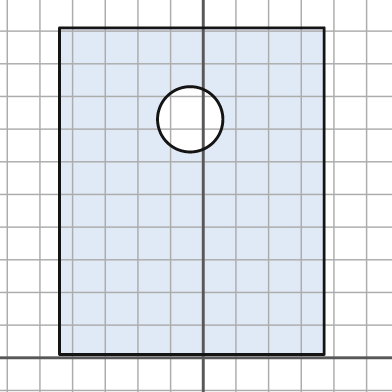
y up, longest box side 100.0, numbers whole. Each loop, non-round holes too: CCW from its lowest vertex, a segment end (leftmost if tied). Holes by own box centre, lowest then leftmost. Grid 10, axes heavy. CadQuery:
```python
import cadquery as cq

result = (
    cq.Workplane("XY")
    .moveTo(-44.0, 1.0)
    .lineTo(37.0, 1.0)
    .lineTo(37.0, 101.0)
    .lineTo(-44.0, 101.0)
    .close()
    .moveTo(-4.0, 73.0)
    .circle(10.0)
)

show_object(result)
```